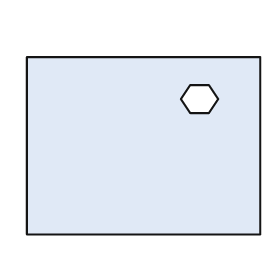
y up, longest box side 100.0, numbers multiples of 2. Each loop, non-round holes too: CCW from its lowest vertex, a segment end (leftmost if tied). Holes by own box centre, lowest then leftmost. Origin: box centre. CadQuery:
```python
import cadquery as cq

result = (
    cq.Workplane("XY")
    .moveTo(-50.0, -38.0)
    .lineTo(50.0, -38.0)
    .lineTo(50.0, 38.0)
    .lineTo(-50.0, 38.0)
    .close()
    .moveTo(20.0, 14.0)
    .lineTo(28.0, 14.0)
    .lineTo(32.0, 20.0)
    .lineTo(28.0, 26.0)
    .lineTo(20.0, 26.0)
    .lineTo(16.0, 20.0)
    .close()
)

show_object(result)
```